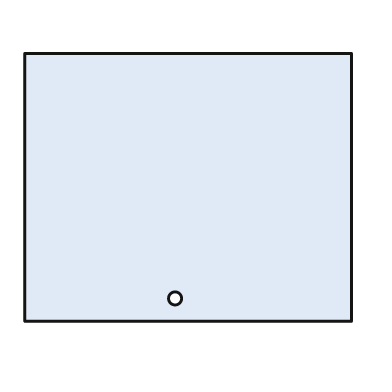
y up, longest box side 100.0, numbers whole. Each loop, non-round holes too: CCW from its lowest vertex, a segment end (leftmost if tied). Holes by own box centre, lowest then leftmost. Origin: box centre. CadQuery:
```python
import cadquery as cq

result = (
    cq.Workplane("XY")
    .moveTo(-50.0, -41.0)
    .lineTo(50.0, -41.0)
    .lineTo(50.0, 41.0)
    .lineTo(-50.0, 41.0)
    .close()
    .moveTo(-4.0, -34.0)
    .circle(2.0)
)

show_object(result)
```